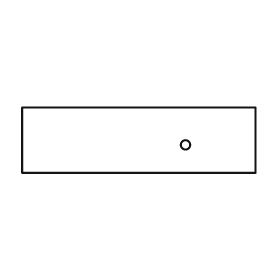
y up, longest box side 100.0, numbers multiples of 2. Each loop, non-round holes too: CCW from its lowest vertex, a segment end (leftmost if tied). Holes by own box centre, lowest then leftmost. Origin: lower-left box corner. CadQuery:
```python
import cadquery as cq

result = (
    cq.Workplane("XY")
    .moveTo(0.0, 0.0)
    .lineTo(100.0, 0.0)
    .lineTo(100.0, 28.0)
    .lineTo(0.0, 28.0)
    .close()
    .moveTo(70.0, 12.0)
    .circle(2.0)
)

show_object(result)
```